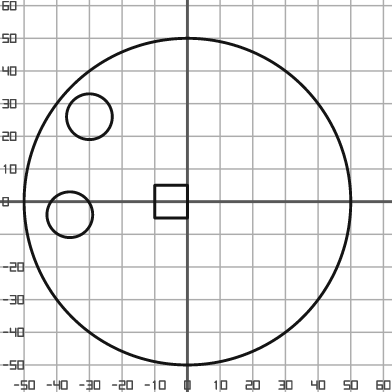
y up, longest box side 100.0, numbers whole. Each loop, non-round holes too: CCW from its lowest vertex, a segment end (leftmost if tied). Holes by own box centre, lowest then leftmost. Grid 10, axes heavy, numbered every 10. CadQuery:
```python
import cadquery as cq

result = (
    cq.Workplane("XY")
    .moveTo(0.0, 0.0)
    .circle(50.0)
    .moveTo(-36.0, -4.0)
    .circle(7.0)
    .moveTo(-10.0, -5.0)
    .lineTo(0.0, -5.0)
    .lineTo(0.0, 5.0)
    .lineTo(-10.0, 5.0)
    .close()
    .moveTo(-30.0, 26.0)
    .circle(7.0)
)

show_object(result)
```